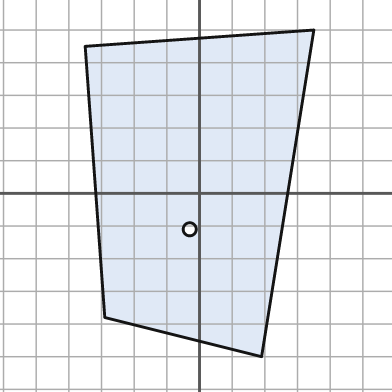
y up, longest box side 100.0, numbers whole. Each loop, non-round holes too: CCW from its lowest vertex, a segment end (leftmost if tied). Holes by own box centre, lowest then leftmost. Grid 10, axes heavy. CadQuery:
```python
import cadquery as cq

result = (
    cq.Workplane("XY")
    .moveTo(19.0, -50.0)
    .lineTo(35.0, 50.0)
    .lineTo(-35.0, 45.0)
    .lineTo(-29.0, -38.0)
    .close()
    .moveTo(-3.0, -11.0)
    .circle(2.0)
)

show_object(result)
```